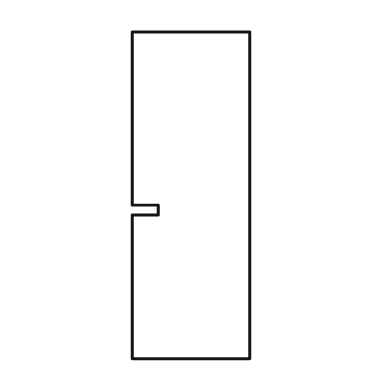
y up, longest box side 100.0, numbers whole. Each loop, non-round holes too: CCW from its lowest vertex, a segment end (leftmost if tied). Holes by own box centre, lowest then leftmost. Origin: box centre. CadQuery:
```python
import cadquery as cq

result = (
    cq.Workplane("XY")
    .moveTo(-18.0, -50.0)
    .lineTo(18.0, -50.0)
    .lineTo(18.0, 50.0)
    .lineTo(-18.0, 50.0)
    .lineTo(-18.0, -3.0)
    .lineTo(-10.0, -3.0)
    .lineTo(-10.0, -6.0)
    .lineTo(-18.0, -6.0)
    .close()
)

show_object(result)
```